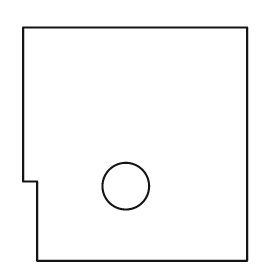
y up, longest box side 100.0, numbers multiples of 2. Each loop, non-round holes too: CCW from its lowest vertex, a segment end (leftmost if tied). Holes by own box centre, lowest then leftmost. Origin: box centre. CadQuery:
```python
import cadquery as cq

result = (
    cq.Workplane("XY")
    .moveTo(-42.0, -50.0)
    .lineTo(48.0, -50.0)
    .lineTo(48.0, 50.0)
    .lineTo(-48.0, 50.0)
    .lineTo(-48.0, -16.0)
    .lineTo(-42.0, -16.0)
    .close()
    .moveTo(-4.0, -18.0)
    .circle(10.0)
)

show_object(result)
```